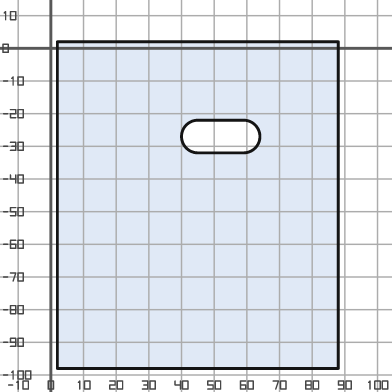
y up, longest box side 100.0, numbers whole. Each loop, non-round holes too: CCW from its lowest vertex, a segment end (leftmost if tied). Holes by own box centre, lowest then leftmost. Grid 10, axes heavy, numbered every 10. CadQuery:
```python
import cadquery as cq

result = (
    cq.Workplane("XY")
    .moveTo(2.0, -98.0)
    .lineTo(88.0, -98.0)
    .lineTo(88.0, 2.0)
    .lineTo(2.0, 2.0)
    .close()
    .moveTo(45.0, -32.0)
    .lineTo(59.0, -32.0)
    .threePointArc((64.0, -27.0), (59.0, -22.0))
    .lineTo(45.0, -22.0)
    .threePointArc((40.0, -27.0), (45.0, -32.0))
    .close()
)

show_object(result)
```